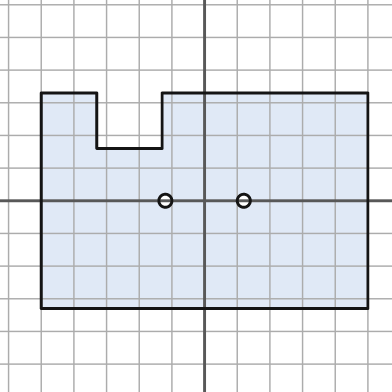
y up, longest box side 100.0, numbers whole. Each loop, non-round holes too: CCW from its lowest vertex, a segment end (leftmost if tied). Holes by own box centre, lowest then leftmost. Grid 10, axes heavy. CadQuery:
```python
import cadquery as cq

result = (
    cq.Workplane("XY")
    .moveTo(-50.0, -33.0)
    .lineTo(50.0, -33.0)
    .lineTo(50.0, 33.0)
    .lineTo(-13.0, 33.0)
    .lineTo(-13.0, 16.0)
    .lineTo(-33.0, 16.0)
    .lineTo(-33.0, 33.0)
    .lineTo(-50.0, 33.0)
    .close()
    .moveTo(-12.0, 0.0)
    .circle(2.0)
    .moveTo(12.0, 0.0)
    .circle(2.0)
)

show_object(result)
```